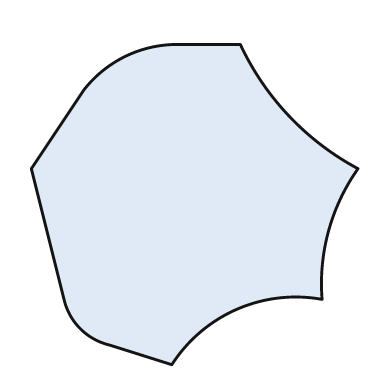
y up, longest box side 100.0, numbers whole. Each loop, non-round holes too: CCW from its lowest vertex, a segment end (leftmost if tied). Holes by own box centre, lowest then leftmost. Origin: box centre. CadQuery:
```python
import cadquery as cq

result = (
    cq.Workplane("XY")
    .moveTo(-7.0, -49.0)
    .threePointArc((13.0, -32.0), (39.0, -29.0))
    .threePointArc((41.0, -8.0), (50.0, 11.0))
    .threePointArc((29.0, 27.0), (14.0, 49.0))
    .lineTo(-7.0, 49.0)
    .threePointArc((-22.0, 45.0), (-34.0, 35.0))
    .lineTo(-50.0, 11.0)
    .lineTo(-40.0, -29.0)
    .threePointArc((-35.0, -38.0), (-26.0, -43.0))
    .close()
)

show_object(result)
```